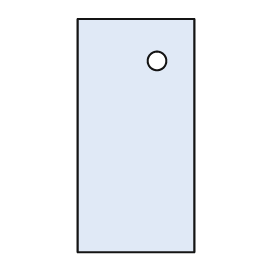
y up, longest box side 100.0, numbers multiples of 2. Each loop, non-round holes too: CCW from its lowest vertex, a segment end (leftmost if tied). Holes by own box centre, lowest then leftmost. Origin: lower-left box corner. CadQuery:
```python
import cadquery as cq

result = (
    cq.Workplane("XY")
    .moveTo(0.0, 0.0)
    .lineTo(50.0, 0.0)
    .lineTo(50.0, 100.0)
    .lineTo(0.0, 100.0)
    .close()
    .moveTo(34.0, 82.0)
    .circle(4.0)
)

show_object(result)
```